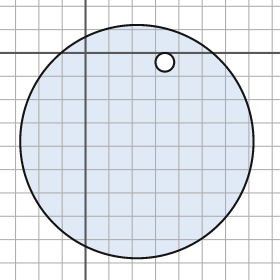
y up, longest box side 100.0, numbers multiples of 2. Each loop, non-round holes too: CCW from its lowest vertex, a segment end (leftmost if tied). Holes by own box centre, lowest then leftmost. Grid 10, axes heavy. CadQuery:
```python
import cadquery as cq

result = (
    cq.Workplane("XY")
    .moveTo(22.0, -38.0)
    .circle(50.0)
    .moveTo(34.0, -4.0)
    .circle(4.0)
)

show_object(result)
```